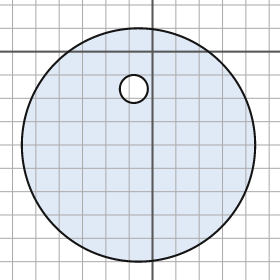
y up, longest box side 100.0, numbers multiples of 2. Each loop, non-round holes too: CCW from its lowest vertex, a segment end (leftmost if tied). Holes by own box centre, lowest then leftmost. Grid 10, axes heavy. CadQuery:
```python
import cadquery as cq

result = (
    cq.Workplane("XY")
    .moveTo(-6.0, -40.0)
    .circle(50.0)
    .moveTo(-8.0, -16.0)
    .circle(6.0)
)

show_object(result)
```